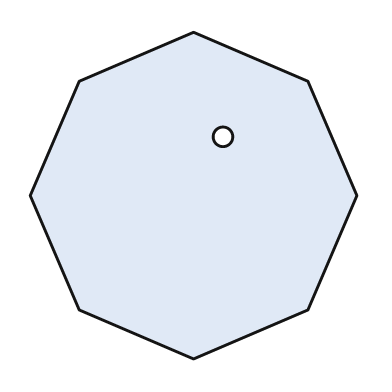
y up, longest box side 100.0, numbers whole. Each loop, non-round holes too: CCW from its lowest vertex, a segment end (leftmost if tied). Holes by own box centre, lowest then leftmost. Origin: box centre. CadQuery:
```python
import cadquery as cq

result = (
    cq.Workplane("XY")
    .moveTo(0.0, -50.0)
    .lineTo(35.0, -35.0)
    .lineTo(50.0, 0.0)
    .lineTo(35.0, 35.0)
    .lineTo(0.0, 50.0)
    .lineTo(-35.0, 35.0)
    .lineTo(-50.0, 0.0)
    .lineTo(-35.0, -35.0)
    .close()
    .moveTo(9.0, 18.0)
    .circle(3.0)
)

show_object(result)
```